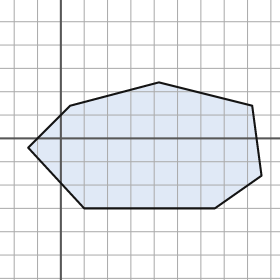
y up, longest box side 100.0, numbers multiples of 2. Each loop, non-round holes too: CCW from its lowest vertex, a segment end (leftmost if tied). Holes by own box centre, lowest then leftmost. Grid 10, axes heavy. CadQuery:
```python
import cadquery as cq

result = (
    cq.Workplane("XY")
    .moveTo(10.0, -30.0)
    .lineTo(66.0, -30.0)
    .lineTo(86.0, -16.0)
    .lineTo(82.0, 14.0)
    .lineTo(42.0, 24.0)
    .lineTo(4.0, 14.0)
    .lineTo(-14.0, -4.0)
    .close()
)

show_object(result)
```